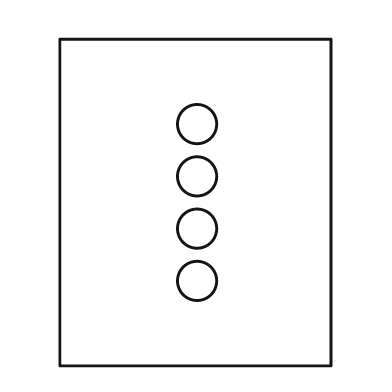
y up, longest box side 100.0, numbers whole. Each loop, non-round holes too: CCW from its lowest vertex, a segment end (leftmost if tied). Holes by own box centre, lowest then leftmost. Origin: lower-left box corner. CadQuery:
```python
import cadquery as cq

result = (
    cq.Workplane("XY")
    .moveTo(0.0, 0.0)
    .lineTo(83.0, 0.0)
    .lineTo(83.0, 100.0)
    .lineTo(0.0, 100.0)
    .close()
    .moveTo(42.0, 26.0)
    .circle(6.0)
    .moveTo(42.0, 42.0)
    .circle(6.0)
    .moveTo(42.0, 58.0)
    .circle(6.0)
    .moveTo(42.0, 74.0)
    .circle(6.0)
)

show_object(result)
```